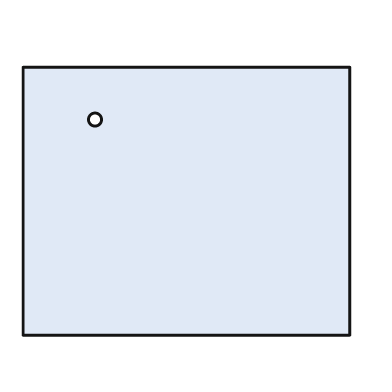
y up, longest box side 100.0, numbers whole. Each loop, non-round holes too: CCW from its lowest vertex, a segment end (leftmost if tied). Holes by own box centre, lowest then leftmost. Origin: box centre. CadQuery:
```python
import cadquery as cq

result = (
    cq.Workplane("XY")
    .moveTo(-50.0, -41.0)
    .lineTo(50.0, -41.0)
    .lineTo(50.0, 41.0)
    .lineTo(-50.0, 41.0)
    .close()
    .moveTo(-28.0, 25.0)
    .circle(2.0)
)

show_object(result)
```